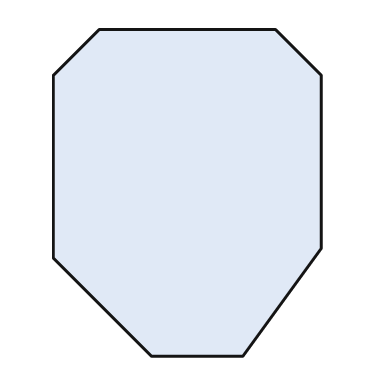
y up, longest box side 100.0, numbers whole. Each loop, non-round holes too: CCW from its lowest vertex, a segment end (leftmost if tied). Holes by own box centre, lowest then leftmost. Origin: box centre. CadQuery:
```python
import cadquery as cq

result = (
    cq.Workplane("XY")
    .moveTo(-11.0, -50.0)
    .lineTo(17.0, -50.0)
    .lineTo(41.0, -17.0)
    .lineTo(41.0, 36.0)
    .lineTo(27.0, 50.0)
    .lineTo(-27.0, 50.0)
    .lineTo(-41.0, 36.0)
    .lineTo(-41.0, -20.0)
    .close()
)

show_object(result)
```